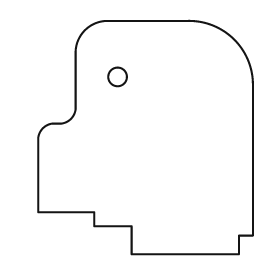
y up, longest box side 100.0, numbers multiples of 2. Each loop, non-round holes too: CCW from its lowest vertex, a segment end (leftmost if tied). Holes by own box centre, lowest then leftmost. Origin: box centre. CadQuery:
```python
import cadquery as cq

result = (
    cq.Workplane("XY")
    .moveTo(-6.0, -50.0)
    .lineTo(40.0, -50.0)
    .lineTo(40.0, -42.0)
    .lineTo(46.0, -42.0)
    .lineTo(46.0, 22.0)
    .threePointArc((38.0, 42.0), (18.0, 50.0))
    .lineTo(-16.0, 50.0)
    .threePointArc((-26.0, 46.0), (-30.0, 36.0))
    .lineTo(-30.0, 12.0)
    .threePointArc((-32.0, 8.0), (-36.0, 6.0))
    .lineTo(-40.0, 6.0)
    .threePointArc((-44.0, 4.0), (-46.0, 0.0))
    .lineTo(-46.0, -32.0)
    .lineTo(-22.0, -32.0)
    .lineTo(-22.0, -38.0)
    .lineTo(-6.0, -38.0)
    .close()
    .moveTo(-12.0, 26.0)
    .circle(4.0)
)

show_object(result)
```